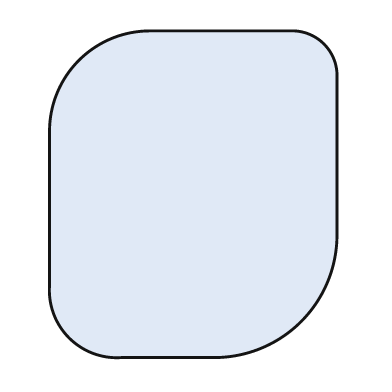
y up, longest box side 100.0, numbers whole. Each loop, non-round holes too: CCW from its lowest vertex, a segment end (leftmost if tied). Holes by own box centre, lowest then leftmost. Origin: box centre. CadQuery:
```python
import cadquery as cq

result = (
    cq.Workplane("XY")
    .moveTo(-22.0, -50.0)
    .lineTo(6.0, -50.0)
    .threePointArc((33.0, -39.0), (44.0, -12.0))
    .lineTo(44.0, 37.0)
    .threePointArc((40.0, 46.0), (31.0, 50.0))
    .lineTo(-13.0, 50.0)
    .threePointArc((-35.0, 41.0), (-44.0, 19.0))
    .lineTo(-44.0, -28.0)
    .threePointArc((-38.0, -44.0), (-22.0, -50.0))
    .close()
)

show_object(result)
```